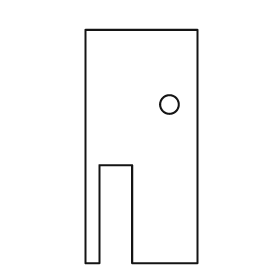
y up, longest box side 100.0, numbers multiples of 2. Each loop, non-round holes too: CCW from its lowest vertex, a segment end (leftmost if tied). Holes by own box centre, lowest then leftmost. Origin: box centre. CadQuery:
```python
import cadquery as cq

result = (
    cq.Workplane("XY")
    .moveTo(-24.0, -50.0)
    .lineTo(-18.0, -50.0)
    .lineTo(-18.0, -8.0)
    .lineTo(-4.0, -8.0)
    .lineTo(-4.0, -50.0)
    .lineTo(24.0, -50.0)
    .lineTo(24.0, 50.0)
    .lineTo(-24.0, 50.0)
    .close()
    .moveTo(12.0, 18.0)
    .circle(4.0)
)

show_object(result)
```